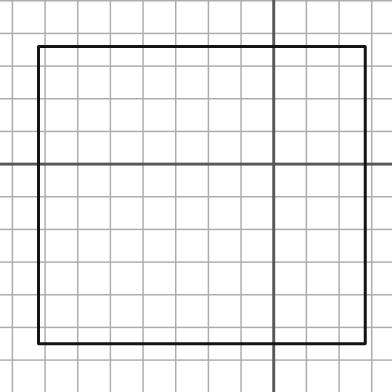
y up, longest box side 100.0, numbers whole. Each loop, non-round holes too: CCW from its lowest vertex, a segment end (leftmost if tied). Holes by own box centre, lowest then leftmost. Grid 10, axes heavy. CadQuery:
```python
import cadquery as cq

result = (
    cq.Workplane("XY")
    .moveTo(-72.0, -55.0)
    .lineTo(28.0, -55.0)
    .lineTo(28.0, 36.0)
    .lineTo(-72.0, 36.0)
    .close()
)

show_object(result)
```